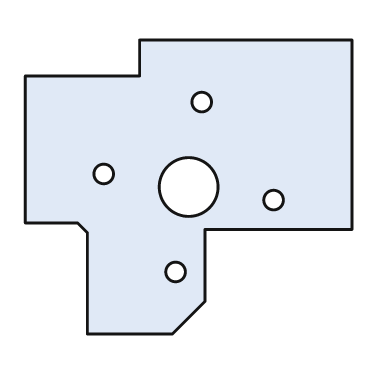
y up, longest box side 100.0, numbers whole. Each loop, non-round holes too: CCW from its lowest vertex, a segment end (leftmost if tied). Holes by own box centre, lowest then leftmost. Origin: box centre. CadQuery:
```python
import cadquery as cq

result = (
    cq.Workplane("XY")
    .moveTo(-31.0, -45.0)
    .lineTo(-5.0, -45.0)
    .lineTo(5.0, -35.0)
    .lineTo(5.0, -13.0)
    .lineTo(50.0, -13.0)
    .lineTo(50.0, 45.0)
    .lineTo(-15.0, 45.0)
    .lineTo(-15.0, 34.0)
    .lineTo(-50.0, 34.0)
    .lineTo(-50.0, -11.0)
    .lineTo(-34.0, -11.0)
    .lineTo(-31.0, -14.0)
    .close()
    .moveTo(-4.0, -26.0)
    .circle(3.0)
    .moveTo(26.0, -4.0)
    .circle(3.0)
    .moveTo(0.0, 0.0)
    .circle(9.0)
    .moveTo(-26.0, 4.0)
    .circle(3.0)
    .moveTo(4.0, 26.0)
    .circle(3.0)
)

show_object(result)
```